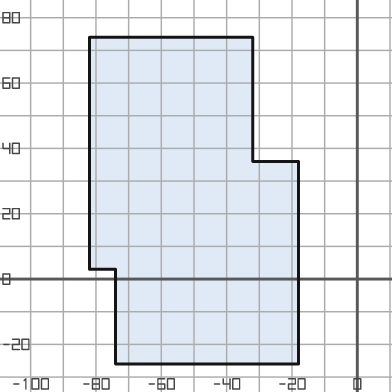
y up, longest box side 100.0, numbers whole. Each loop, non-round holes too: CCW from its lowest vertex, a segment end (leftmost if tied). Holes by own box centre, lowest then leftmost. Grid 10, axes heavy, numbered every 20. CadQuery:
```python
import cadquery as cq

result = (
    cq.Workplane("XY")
    .moveTo(-74.0, -26.0)
    .lineTo(-18.0, -26.0)
    .lineTo(-18.0, 36.0)
    .lineTo(-32.0, 36.0)
    .lineTo(-32.0, 74.0)
    .lineTo(-82.0, 74.0)
    .lineTo(-82.0, 3.0)
    .lineTo(-74.0, 3.0)
    .close()
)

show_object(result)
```